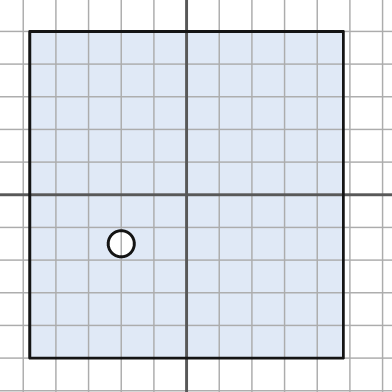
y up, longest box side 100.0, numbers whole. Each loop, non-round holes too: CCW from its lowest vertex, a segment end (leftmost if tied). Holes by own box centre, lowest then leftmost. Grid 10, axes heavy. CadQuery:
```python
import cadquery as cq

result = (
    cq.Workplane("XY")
    .moveTo(-48.0, -50.0)
    .lineTo(48.0, -50.0)
    .lineTo(48.0, 50.0)
    .lineTo(-48.0, 50.0)
    .close()
    .moveTo(-20.0, -15.0)
    .circle(4.0)
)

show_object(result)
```